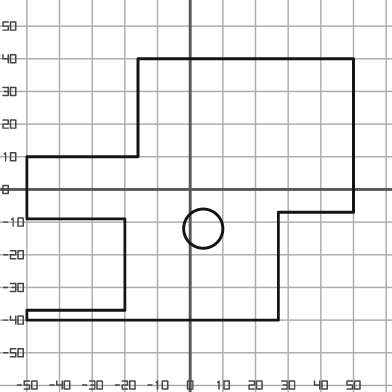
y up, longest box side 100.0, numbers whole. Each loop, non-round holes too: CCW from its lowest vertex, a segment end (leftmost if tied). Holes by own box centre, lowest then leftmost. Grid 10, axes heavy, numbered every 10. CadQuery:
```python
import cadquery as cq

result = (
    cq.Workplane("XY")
    .moveTo(-50.0, -40.0)
    .lineTo(27.0, -40.0)
    .lineTo(27.0, -7.0)
    .lineTo(50.0, -7.0)
    .lineTo(50.0, 40.0)
    .lineTo(-16.0, 40.0)
    .lineTo(-16.0, 10.0)
    .lineTo(-50.0, 10.0)
    .lineTo(-50.0, -9.0)
    .lineTo(-20.0, -9.0)
    .lineTo(-20.0, -37.0)
    .lineTo(-50.0, -37.0)
    .close()
    .moveTo(4.0, -12.0)
    .circle(6.0)
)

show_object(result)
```